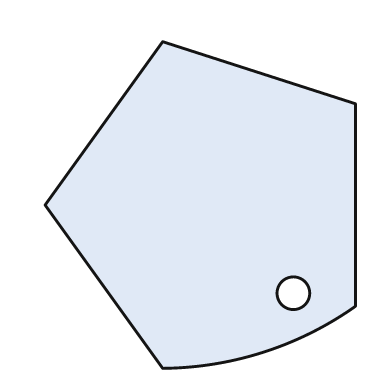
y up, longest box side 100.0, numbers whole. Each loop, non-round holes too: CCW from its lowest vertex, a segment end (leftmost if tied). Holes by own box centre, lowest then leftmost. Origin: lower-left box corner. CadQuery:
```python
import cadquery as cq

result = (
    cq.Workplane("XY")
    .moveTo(36.0, 0.0)
    .threePointArc((67.0, 5.0), (95.0, 19.0))
    .lineTo(95.0, 81.0)
    .lineTo(36.0, 100.0)
    .lineTo(0.0, 50.0)
    .close()
    .moveTo(76.0, 23.0)
    .circle(5.0)
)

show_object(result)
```